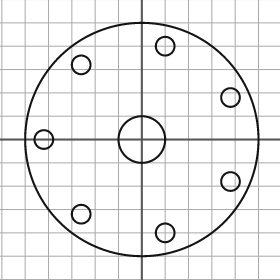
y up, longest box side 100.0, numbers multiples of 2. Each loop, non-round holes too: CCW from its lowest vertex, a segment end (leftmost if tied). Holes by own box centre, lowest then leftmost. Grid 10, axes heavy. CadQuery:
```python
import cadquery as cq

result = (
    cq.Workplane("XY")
    .moveTo(0.0, 0.0)
    .circle(50.0)
    .moveTo(10.0, -40.0)
    .circle(4.0)
    .moveTo(-26.0, -32.0)
    .circle(4.0)
    .moveTo(38.0, -18.0)
    .circle(4.0)
    .moveTo(-42.0, 0.0)
    .circle(4.0)
    .moveTo(0.0, 0.0)
    .circle(10.0)
    .moveTo(38.0, 18.0)
    .circle(4.0)
    .moveTo(-26.0, 32.0)
    .circle(4.0)
    .moveTo(10.0, 40.0)
    .circle(4.0)
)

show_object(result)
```